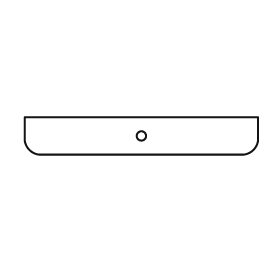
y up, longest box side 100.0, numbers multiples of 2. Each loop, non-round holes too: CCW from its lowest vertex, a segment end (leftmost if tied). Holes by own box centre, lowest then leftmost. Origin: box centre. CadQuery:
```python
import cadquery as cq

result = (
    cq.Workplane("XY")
    .moveTo(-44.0, -8.0)
    .lineTo(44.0, -8.0)
    .threePointArc((48.0, -6.0), (50.0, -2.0))
    .lineTo(50.0, 8.0)
    .lineTo(-50.0, 8.0)
    .lineTo(-50.0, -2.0)
    .threePointArc((-48.0, -6.0), (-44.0, -8.0))
    .close()
    .moveTo(0.0, 0.0)
    .circle(2.0)
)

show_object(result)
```